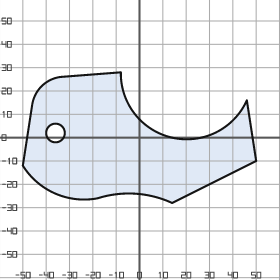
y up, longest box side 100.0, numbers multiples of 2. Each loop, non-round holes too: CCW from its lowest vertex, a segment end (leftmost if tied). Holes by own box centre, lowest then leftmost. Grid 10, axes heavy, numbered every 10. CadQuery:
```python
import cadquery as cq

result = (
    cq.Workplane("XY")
    .moveTo(14.0, -28.0)
    .lineTo(50.0, -10.0)
    .lineTo(46.0, 16.0)
    .threePointArc((14.0, 0.0), (-8.0, 28.0))
    .lineTo(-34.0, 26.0)
    .threePointArc((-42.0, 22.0), (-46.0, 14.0))
    .lineTo(-50.0, -12.0)
    .threePointArc((-36.0, -24.0), (-18.0, -26.0))
    .threePointArc((-2.0, -24.0), (14.0, -28.0))
    .close()
    .moveTo(-36.0, 2.0)
    .circle(4.0)
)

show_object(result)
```